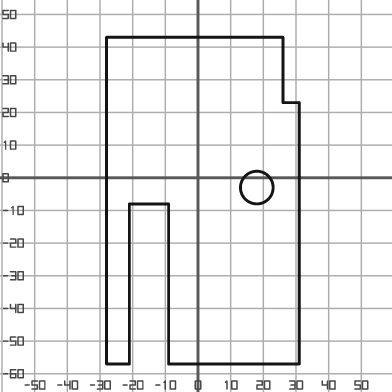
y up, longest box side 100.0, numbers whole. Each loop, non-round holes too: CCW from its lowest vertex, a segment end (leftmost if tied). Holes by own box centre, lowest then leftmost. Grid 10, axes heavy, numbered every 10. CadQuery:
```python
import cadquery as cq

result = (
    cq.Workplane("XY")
    .moveTo(-28.0, -57.0)
    .lineTo(-21.0, -57.0)
    .lineTo(-21.0, -8.0)
    .lineTo(-9.0, -8.0)
    .lineTo(-9.0, -57.0)
    .lineTo(31.0, -57.0)
    .lineTo(31.0, 23.0)
    .lineTo(26.0, 23.0)
    .lineTo(26.0, 43.0)
    .lineTo(-28.0, 43.0)
    .close()
    .moveTo(18.0, -3.0)
    .circle(5.0)
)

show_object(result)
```